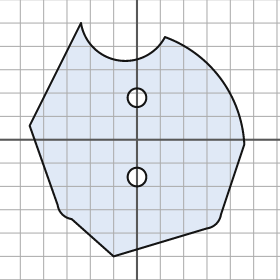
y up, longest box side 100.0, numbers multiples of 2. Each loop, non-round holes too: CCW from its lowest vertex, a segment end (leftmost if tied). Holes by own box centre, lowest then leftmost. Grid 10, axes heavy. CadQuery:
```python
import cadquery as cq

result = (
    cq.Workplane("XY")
    .moveTo(-10.0, -50.0)
    .lineTo(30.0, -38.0)
    .threePointArc((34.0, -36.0), (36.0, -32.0))
    .lineTo(46.0, -2.0)
    .threePointArc((36.0, 26.0), (12.0, 44.0))
    .threePointArc((-8.0, 34.0), (-24.0, 50.0))
    .lineTo(-46.0, 6.0)
    .lineTo(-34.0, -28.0)
    .threePointArc((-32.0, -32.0), (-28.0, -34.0))
    .close()
    .moveTo(0.0, -16.0)
    .circle(4.0)
    .moveTo(0.0, 18.0)
    .circle(4.0)
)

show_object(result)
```